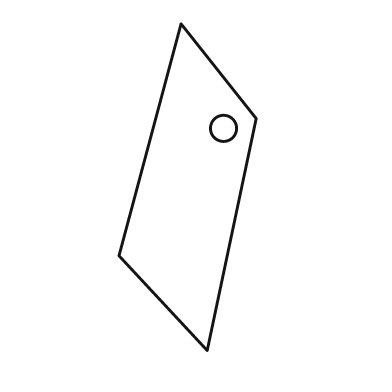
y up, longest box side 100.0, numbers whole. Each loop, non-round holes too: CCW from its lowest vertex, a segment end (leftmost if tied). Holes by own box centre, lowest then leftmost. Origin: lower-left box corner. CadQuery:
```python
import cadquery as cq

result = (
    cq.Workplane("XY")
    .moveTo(27.0, 0.0)
    .lineTo(42.0, 71.0)
    .lineTo(19.0, 100.0)
    .lineTo(0.0, 29.0)
    .close()
    .moveTo(32.0, 68.0)
    .circle(4.0)
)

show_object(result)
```